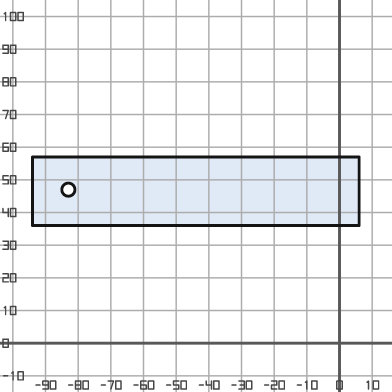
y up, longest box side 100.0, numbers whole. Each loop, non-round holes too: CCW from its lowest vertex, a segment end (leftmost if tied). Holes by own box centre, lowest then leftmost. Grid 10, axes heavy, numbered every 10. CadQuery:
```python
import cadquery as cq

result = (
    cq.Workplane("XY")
    .moveTo(-94.0, 36.0)
    .lineTo(6.0, 36.0)
    .lineTo(6.0, 57.0)
    .lineTo(-94.0, 57.0)
    .close()
    .moveTo(-83.0, 47.0)
    .circle(2.0)
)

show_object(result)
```